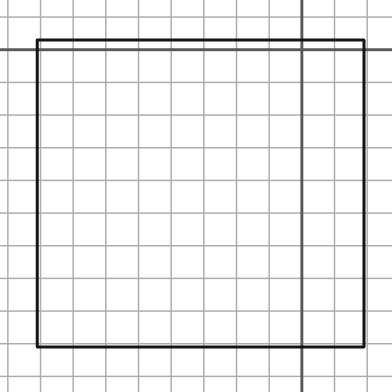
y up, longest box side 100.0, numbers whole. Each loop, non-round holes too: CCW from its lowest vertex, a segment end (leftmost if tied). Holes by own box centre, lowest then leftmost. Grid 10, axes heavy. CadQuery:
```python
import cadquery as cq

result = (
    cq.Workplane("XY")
    .moveTo(-81.0, -91.0)
    .lineTo(19.0, -91.0)
    .lineTo(19.0, 3.0)
    .lineTo(-81.0, 3.0)
    .close()
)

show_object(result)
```